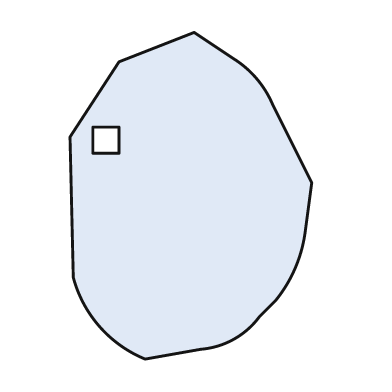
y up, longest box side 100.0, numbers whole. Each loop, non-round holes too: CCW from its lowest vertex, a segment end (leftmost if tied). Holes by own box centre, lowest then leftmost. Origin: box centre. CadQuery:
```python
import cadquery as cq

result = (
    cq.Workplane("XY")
    .moveTo(-14.0, -50.0)
    .lineTo(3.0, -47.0)
    .threePointArc((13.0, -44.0), (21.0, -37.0))
    .lineTo(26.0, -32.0)
    .threePointArc((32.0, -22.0), (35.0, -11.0))
    .lineTo(37.0, 4.0)
    .lineTo(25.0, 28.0)
    .threePointArc((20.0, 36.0), (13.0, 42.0))
    .lineTo(1.0, 50.0)
    .lineTo(-22.0, 41.0)
    .lineTo(-37.0, 18.0)
    .lineTo(-36.0, -25.0)
    .threePointArc((-28.0, -40.0), (-14.0, -50.0))
    .close()
    .moveTo(-30.0, 13.0)
    .lineTo(-22.0, 13.0)
    .lineTo(-22.0, 21.0)
    .lineTo(-30.0, 21.0)
    .close()
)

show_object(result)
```